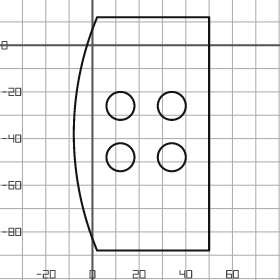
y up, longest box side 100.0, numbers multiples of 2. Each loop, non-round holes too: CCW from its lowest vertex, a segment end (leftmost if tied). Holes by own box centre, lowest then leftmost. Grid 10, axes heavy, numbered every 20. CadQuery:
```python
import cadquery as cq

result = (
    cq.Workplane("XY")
    .moveTo(2.0, -88.0)
    .lineTo(50.0, -88.0)
    .lineTo(50.0, 12.0)
    .lineTo(2.0, 12.0)
    .threePointArc((-8.0, -38.0), (2.0, -88.0))
    .close()
    .moveTo(12.0, -48.0)
    .circle(6.0)
    .moveTo(34.0, -48.0)
    .circle(6.0)
    .moveTo(12.0, -26.0)
    .circle(6.0)
    .moveTo(34.0, -26.0)
    .circle(6.0)
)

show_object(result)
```